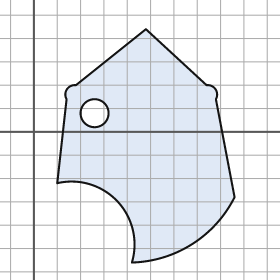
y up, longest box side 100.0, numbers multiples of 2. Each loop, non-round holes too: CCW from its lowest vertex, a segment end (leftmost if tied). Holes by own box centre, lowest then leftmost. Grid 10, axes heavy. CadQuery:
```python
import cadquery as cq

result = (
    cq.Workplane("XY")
    .moveTo(42.0, -56.0)
    .threePointArc((68.0, -48.0), (86.0, -28.0))
    .lineTo(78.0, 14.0)
    .threePointArc((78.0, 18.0), (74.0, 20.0))
    .lineTo(48.0, 44.0)
    .lineTo(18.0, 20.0)
    .threePointArc((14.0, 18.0), (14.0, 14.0))
    .lineTo(10.0, -22.0)
    .threePointArc((36.0, -30.0), (42.0, -56.0))
    .close()
    .moveTo(26.0, 8.0)
    .circle(6.0)
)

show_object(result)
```